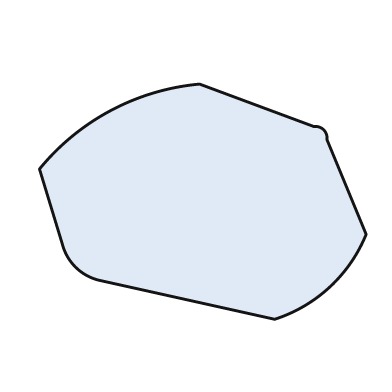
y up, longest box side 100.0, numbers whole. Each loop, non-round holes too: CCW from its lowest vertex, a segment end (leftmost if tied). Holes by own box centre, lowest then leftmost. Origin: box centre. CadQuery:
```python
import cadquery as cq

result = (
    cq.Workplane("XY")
    .moveTo(22.0, -36.0)
    .threePointArc((39.0, -26.0), (50.0, -10.0))
    .lineTo(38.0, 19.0)
    .threePointArc((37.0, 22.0), (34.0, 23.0))
    .lineTo(-1.0, 36.0)
    .threePointArc((-28.0, 28.0), (-50.0, 10.0))
    .lineTo(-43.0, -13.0)
    .threePointArc((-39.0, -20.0), (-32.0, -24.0))
    .close()
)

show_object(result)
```